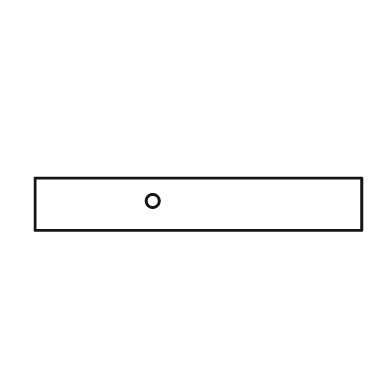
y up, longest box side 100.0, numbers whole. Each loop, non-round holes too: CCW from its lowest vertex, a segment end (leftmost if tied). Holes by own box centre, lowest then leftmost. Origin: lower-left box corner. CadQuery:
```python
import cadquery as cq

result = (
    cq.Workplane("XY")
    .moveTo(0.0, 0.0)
    .lineTo(100.0, 0.0)
    .lineTo(100.0, 16.0)
    .lineTo(0.0, 16.0)
    .close()
    .moveTo(36.0, 9.0)
    .circle(2.0)
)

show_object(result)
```